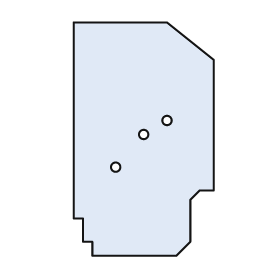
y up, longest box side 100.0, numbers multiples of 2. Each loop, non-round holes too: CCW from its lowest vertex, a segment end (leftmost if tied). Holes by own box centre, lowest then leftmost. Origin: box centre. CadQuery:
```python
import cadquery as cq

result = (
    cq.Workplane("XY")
    .moveTo(-22.0, -50.0)
    .lineTo(14.0, -50.0)
    .lineTo(20.0, -44.0)
    .lineTo(20.0, -26.0)
    .lineTo(24.0, -22.0)
    .lineTo(30.0, -22.0)
    .lineTo(30.0, 34.0)
    .lineTo(10.0, 50.0)
    .lineTo(-30.0, 50.0)
    .lineTo(-30.0, -34.0)
    .lineTo(-26.0, -34.0)
    .lineTo(-26.0, -44.0)
    .lineTo(-22.0, -44.0)
    .close()
    .moveTo(-12.0, -12.0)
    .circle(2.0)
    .moveTo(0.0, 2.0)
    .circle(2.0)
    .moveTo(10.0, 8.0)
    .circle(2.0)
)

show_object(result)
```